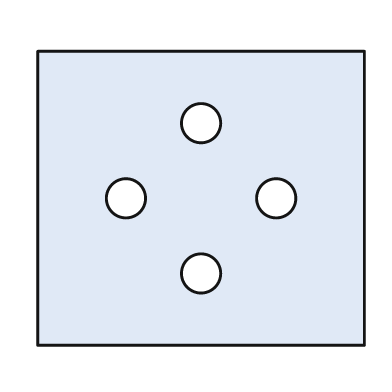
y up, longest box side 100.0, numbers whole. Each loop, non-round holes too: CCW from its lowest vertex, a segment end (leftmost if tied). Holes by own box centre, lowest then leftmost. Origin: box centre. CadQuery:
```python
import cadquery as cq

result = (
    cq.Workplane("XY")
    .moveTo(-50.0, -45.0)
    .lineTo(50.0, -45.0)
    .lineTo(50.0, 45.0)
    .lineTo(-50.0, 45.0)
    .close()
    .moveTo(0.0, -23.0)
    .circle(6.0)
    .moveTo(-23.0, 0.0)
    .circle(6.0)
    .moveTo(23.0, 0.0)
    .circle(6.0)
    .moveTo(0.0, 23.0)
    .circle(6.0)
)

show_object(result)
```